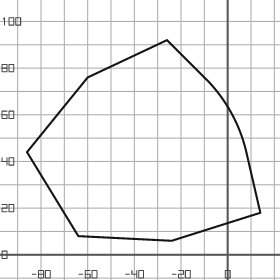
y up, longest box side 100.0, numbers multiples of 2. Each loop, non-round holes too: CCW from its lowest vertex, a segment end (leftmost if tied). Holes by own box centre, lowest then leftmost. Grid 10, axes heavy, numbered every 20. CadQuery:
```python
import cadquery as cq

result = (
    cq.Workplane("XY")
    .moveTo(-24.0, 6.0)
    .lineTo(14.0, 18.0)
    .lineTo(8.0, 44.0)
    .threePointArc((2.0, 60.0), (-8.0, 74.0))
    .lineTo(-26.0, 92.0)
    .lineTo(-60.0, 76.0)
    .lineTo(-86.0, 44.0)
    .lineTo(-64.0, 8.0)
    .close()
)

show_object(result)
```